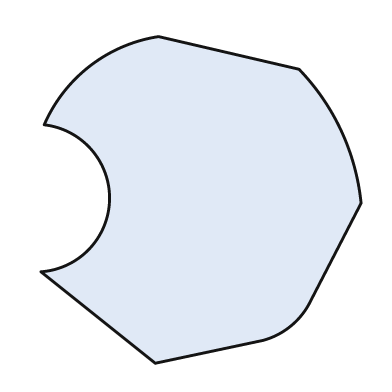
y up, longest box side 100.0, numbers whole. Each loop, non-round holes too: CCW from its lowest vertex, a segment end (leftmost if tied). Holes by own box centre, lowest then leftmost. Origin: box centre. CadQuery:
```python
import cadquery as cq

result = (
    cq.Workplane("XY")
    .moveTo(-14.0, -50.0)
    .lineTo(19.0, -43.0)
    .threePointArc((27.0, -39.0), (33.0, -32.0))
    .lineTo(49.0, -1.0)
    .threePointArc((43.0, 21.0), (30.0, 40.0))
    .lineTo(-13.0, 50.0)
    .threePointArc((-34.0, 41.0), (-48.0, 23.0))
    .threePointArc((-28.0, 0.0), (-49.0, -22.0))
    .close()
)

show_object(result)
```